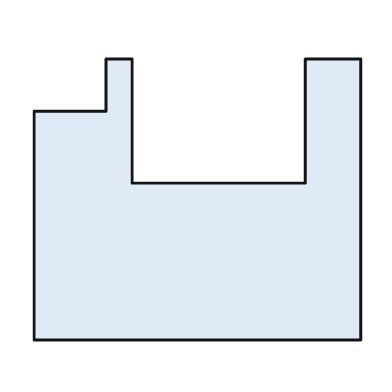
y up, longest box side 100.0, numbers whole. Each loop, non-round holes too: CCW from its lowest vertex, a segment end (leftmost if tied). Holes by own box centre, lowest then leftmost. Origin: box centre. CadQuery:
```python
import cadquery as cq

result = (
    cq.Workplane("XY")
    .moveTo(-50.0, -43.0)
    .lineTo(50.0, -43.0)
    .lineTo(50.0, 43.0)
    .lineTo(33.0, 43.0)
    .lineTo(33.0, 5.0)
    .lineTo(-20.0, 5.0)
    .lineTo(-20.0, 43.0)
    .lineTo(-28.0, 43.0)
    .lineTo(-28.0, 27.0)
    .lineTo(-50.0, 27.0)
    .close()
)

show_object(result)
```